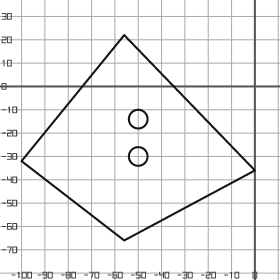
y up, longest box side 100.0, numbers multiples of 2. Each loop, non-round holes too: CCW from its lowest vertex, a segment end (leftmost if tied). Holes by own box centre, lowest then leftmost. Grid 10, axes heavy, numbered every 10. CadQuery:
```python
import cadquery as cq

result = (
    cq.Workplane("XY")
    .moveTo(-56.0, -66.0)
    .lineTo(0.0, -36.0)
    .lineTo(-56.0, 22.0)
    .lineTo(-100.0, -32.0)
    .close()
    .moveTo(-50.0, -30.0)
    .circle(4.0)
    .moveTo(-50.0, -14.0)
    .circle(4.0)
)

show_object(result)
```